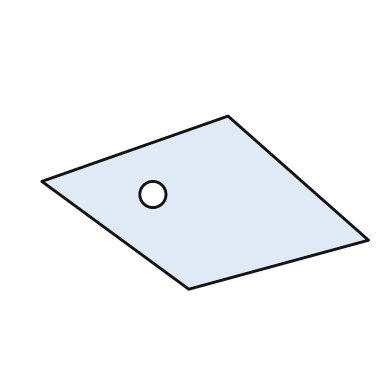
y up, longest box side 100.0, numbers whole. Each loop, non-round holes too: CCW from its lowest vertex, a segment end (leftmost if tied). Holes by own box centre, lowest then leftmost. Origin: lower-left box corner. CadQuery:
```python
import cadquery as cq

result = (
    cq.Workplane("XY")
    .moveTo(45.0, 0.0)
    .lineTo(100.0, 15.0)
    .lineTo(57.0, 53.0)
    .lineTo(0.0, 33.0)
    .close()
    .moveTo(34.0, 29.0)
    .circle(4.0)
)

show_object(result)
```